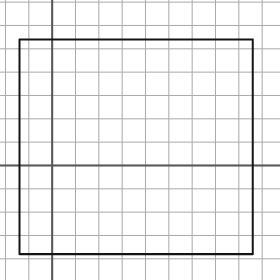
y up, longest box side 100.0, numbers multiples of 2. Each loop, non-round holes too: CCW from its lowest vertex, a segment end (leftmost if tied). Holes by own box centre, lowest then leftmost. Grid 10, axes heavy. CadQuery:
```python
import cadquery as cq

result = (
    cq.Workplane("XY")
    .moveTo(-14.0, -38.0)
    .lineTo(86.0, -38.0)
    .lineTo(86.0, 54.0)
    .lineTo(-14.0, 54.0)
    .close()
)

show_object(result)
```